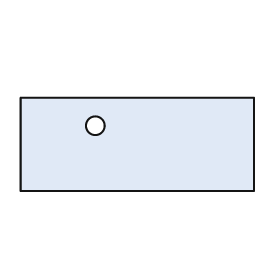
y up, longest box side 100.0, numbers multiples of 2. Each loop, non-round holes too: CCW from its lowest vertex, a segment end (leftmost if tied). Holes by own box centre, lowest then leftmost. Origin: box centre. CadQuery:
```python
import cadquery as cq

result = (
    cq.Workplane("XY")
    .moveTo(-50.0, -20.0)
    .lineTo(50.0, -20.0)
    .lineTo(50.0, 20.0)
    .lineTo(-50.0, 20.0)
    .close()
    .moveTo(-18.0, 8.0)
    .circle(4.0)
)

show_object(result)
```